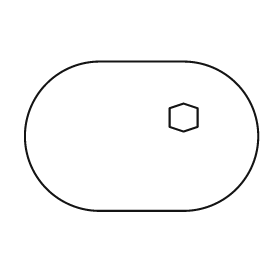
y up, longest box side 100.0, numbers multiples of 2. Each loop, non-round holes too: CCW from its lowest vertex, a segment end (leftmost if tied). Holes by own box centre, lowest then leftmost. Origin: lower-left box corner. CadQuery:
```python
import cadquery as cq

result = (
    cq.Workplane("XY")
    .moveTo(32.0, 0.0)
    .lineTo(68.0, 0.0)
    .threePointArc((100.0, 32.0), (68.0, 64.0))
    .lineTo(32.0, 64.0)
    .threePointArc((0.0, 32.0), (32.0, 0.0))
    .close()
    .moveTo(68.0, 34.0)
    .lineTo(74.0, 36.0)
    .lineTo(74.0, 44.0)
    .lineTo(68.0, 46.0)
    .lineTo(62.0, 44.0)
    .lineTo(62.0, 36.0)
    .close()
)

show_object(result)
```